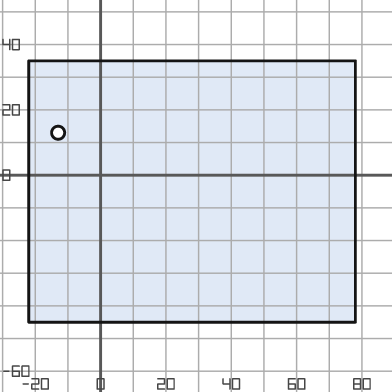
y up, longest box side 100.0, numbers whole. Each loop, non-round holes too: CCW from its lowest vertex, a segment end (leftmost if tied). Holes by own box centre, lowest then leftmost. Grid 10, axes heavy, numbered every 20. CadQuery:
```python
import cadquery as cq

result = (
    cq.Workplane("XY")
    .moveTo(-22.0, -45.0)
    .lineTo(78.0, -45.0)
    .lineTo(78.0, 35.0)
    .lineTo(-22.0, 35.0)
    .close()
    .moveTo(-13.0, 13.0)
    .circle(2.0)
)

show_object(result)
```